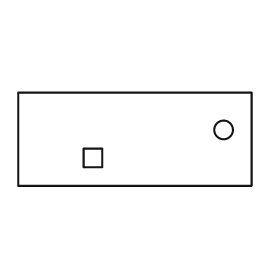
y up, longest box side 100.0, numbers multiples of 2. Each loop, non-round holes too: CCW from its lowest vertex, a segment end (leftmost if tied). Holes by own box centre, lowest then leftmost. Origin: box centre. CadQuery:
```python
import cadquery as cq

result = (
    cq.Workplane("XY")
    .moveTo(-50.0, -20.0)
    .lineTo(50.0, -20.0)
    .lineTo(50.0, 20.0)
    .lineTo(-50.0, 20.0)
    .close()
    .moveTo(-22.0, -12.0)
    .lineTo(-14.0, -12.0)
    .lineTo(-14.0, -4.0)
    .lineTo(-22.0, -4.0)
    .close()
    .moveTo(38.0, 4.0)
    .circle(4.0)
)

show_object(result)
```